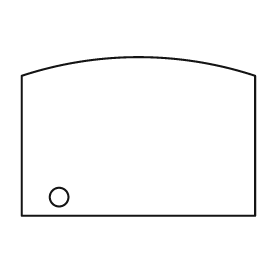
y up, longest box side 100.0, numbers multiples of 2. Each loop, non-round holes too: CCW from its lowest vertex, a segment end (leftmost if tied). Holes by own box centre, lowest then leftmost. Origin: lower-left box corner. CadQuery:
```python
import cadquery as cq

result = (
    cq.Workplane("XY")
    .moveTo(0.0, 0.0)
    .lineTo(100.0, 0.0)
    .lineTo(100.0, 60.0)
    .threePointArc((50.0, 68.0), (0.0, 60.0))
    .close()
    .moveTo(16.0, 8.0)
    .circle(4.0)
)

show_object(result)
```